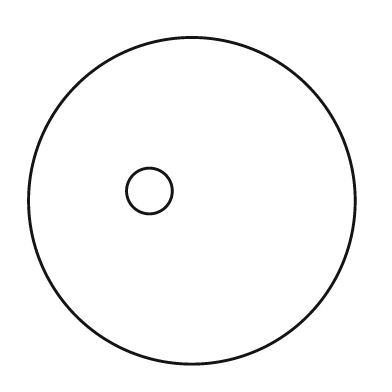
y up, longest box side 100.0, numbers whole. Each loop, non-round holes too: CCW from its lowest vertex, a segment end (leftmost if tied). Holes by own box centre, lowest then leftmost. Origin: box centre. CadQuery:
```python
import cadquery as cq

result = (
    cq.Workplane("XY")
    .moveTo(0.0, 0.0)
    .circle(50.0)
    .moveTo(-13.0, 3.0)
    .circle(7.0)
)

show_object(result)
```